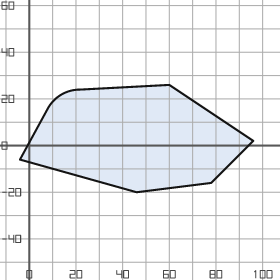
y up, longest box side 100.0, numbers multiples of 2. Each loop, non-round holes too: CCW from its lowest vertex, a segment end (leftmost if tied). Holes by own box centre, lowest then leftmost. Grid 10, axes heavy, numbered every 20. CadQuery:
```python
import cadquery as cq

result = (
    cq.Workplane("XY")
    .moveTo(46.0, -20.0)
    .lineTo(78.0, -16.0)
    .lineTo(96.0, 2.0)
    .lineTo(60.0, 26.0)
    .lineTo(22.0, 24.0)
    .threePointArc((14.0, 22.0), (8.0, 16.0))
    .lineTo(-4.0, -6.0)
    .close()
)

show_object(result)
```